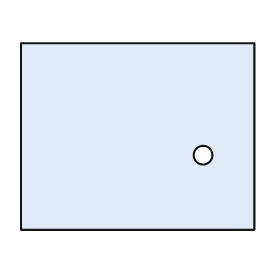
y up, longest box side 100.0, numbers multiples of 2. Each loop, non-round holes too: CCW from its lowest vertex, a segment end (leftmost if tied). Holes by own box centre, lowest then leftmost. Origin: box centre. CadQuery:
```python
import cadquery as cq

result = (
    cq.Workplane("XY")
    .moveTo(-50.0, -40.0)
    .lineTo(50.0, -40.0)
    .lineTo(50.0, 40.0)
    .lineTo(-50.0, 40.0)
    .close()
    .moveTo(28.0, -8.0)
    .circle(4.0)
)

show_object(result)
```